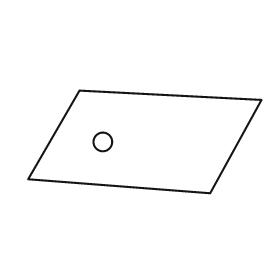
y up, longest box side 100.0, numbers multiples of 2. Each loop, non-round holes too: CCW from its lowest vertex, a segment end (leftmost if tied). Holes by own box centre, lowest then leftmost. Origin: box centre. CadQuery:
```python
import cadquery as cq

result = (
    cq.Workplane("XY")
    .moveTo(28.0, -22.0)
    .lineTo(50.0, 18.0)
    .lineTo(-28.0, 22.0)
    .lineTo(-50.0, -16.0)
    .close()
    .moveTo(-18.0, 0.0)
    .circle(4.0)
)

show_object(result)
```